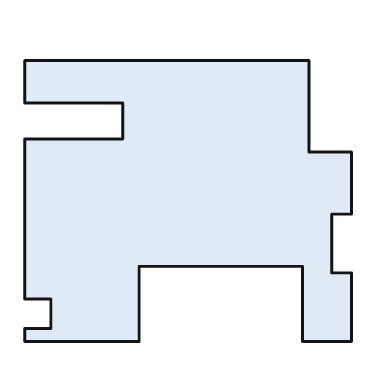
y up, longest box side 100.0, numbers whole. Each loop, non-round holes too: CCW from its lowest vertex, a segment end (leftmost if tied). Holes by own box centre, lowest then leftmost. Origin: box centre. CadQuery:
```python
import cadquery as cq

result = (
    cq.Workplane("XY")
    .moveTo(-50.0, -43.0)
    .lineTo(-15.0, -43.0)
    .lineTo(-15.0, -20.0)
    .lineTo(35.0, -20.0)
    .lineTo(35.0, -43.0)
    .lineTo(50.0, -43.0)
    .lineTo(50.0, -22.0)
    .lineTo(44.0, -22.0)
    .lineTo(44.0, -4.0)
    .lineTo(50.0, -4.0)
    .lineTo(50.0, 15.0)
    .lineTo(37.0, 15.0)
    .lineTo(37.0, 43.0)
    .lineTo(-50.0, 43.0)
    .lineTo(-50.0, 30.0)
    .lineTo(-20.0, 30.0)
    .lineTo(-20.0, 19.0)
    .lineTo(-50.0, 19.0)
    .lineTo(-50.0, -30.0)
    .lineTo(-42.0, -30.0)
    .lineTo(-42.0, -39.0)
    .lineTo(-50.0, -39.0)
    .close()
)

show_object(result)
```